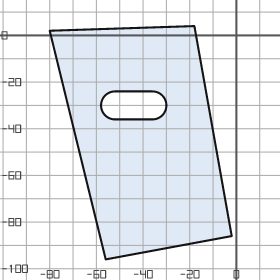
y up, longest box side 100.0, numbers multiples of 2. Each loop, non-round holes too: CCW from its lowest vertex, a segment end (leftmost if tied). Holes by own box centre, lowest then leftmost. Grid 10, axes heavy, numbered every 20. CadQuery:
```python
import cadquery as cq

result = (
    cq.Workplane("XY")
    .moveTo(-56.0, -96.0)
    .lineTo(-2.0, -86.0)
    .lineTo(-18.0, 4.0)
    .lineTo(-80.0, 2.0)
    .close()
    .moveTo(-52.0, -36.0)
    .lineTo(-36.0, -36.0)
    .threePointArc((-30.0, -30.0), (-36.0, -24.0))
    .lineTo(-52.0, -24.0)
    .threePointArc((-58.0, -30.0), (-52.0, -36.0))
    .close()
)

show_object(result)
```